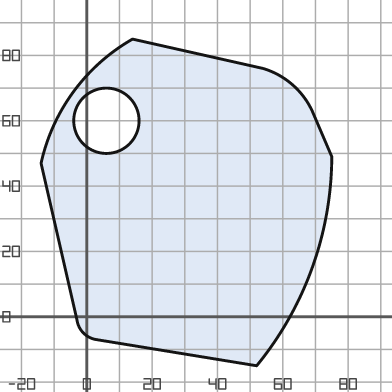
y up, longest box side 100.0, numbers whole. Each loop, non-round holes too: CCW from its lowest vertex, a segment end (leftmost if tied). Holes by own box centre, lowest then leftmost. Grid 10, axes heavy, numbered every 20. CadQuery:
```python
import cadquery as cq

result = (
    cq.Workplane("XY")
    .moveTo(52.0, -15.0)
    .threePointArc((69.0, 15.0), (75.0, 49.0))
    .lineTo(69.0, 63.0)
    .threePointArc((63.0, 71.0), (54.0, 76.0))
    .lineTo(14.0, 85.0)
    .threePointArc((-4.0, 69.0), (-14.0, 47.0))
    .lineTo(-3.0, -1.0)
    .threePointArc((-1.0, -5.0), (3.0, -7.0))
    .close()
    .moveTo(6.0, 60.0)
    .circle(10.0)
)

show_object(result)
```